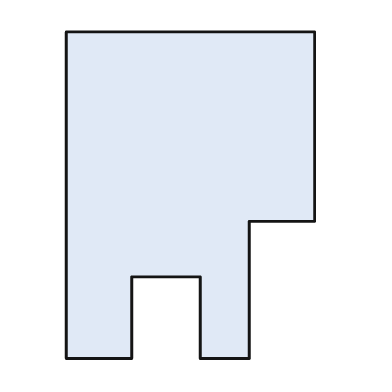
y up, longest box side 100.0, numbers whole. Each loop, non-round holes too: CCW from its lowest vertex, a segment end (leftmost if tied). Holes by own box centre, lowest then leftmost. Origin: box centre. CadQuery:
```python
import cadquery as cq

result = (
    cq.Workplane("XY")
    .moveTo(-38.0, -50.0)
    .lineTo(-18.0, -50.0)
    .lineTo(-18.0, -25.0)
    .lineTo(3.0, -25.0)
    .lineTo(3.0, -50.0)
    .lineTo(18.0, -50.0)
    .lineTo(18.0, -8.0)
    .lineTo(38.0, -8.0)
    .lineTo(38.0, 50.0)
    .lineTo(-38.0, 50.0)
    .close()
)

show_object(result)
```